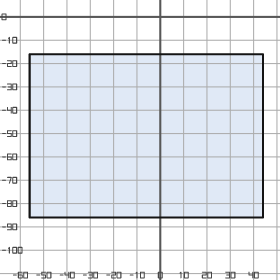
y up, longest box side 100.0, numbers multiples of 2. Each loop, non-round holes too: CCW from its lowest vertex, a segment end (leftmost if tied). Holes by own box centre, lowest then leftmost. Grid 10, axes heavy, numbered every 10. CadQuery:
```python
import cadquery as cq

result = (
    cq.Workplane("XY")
    .moveTo(-56.0, -86.0)
    .lineTo(44.0, -86.0)
    .lineTo(44.0, -16.0)
    .lineTo(-56.0, -16.0)
    .close()
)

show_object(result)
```